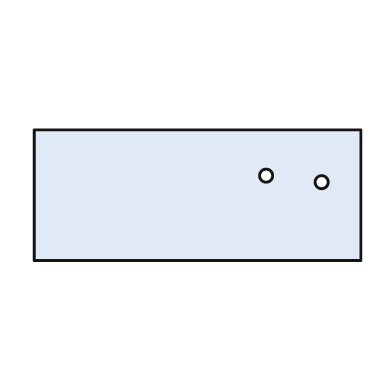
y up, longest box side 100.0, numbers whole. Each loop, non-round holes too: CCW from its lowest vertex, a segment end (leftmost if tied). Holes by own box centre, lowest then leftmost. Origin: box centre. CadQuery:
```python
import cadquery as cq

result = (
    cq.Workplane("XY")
    .moveTo(-50.0, -20.0)
    .lineTo(50.0, -20.0)
    .lineTo(50.0, 20.0)
    .lineTo(-50.0, 20.0)
    .close()
    .moveTo(38.0, 4.0)
    .circle(2.0)
    .moveTo(21.0, 6.0)
    .circle(2.0)
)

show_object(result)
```